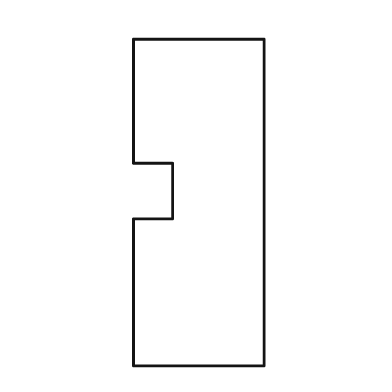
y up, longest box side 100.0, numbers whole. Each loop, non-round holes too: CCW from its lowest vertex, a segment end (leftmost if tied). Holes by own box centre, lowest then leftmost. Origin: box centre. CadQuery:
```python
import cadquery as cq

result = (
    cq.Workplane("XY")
    .moveTo(-20.0, -50.0)
    .lineTo(20.0, -50.0)
    .lineTo(20.0, 50.0)
    .lineTo(-20.0, 50.0)
    .lineTo(-20.0, 12.0)
    .lineTo(-8.0, 12.0)
    .lineTo(-8.0, -5.0)
    .lineTo(-20.0, -5.0)
    .close()
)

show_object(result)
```